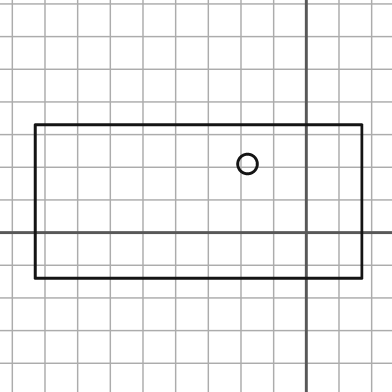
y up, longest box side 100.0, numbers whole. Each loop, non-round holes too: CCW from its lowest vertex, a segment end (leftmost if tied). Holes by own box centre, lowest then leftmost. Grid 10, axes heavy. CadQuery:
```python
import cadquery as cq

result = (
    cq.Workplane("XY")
    .moveTo(-83.0, -14.0)
    .lineTo(17.0, -14.0)
    .lineTo(17.0, 33.0)
    .lineTo(-83.0, 33.0)
    .close()
    .moveTo(-18.0, 21.0)
    .circle(3.0)
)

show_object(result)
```